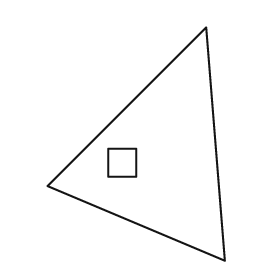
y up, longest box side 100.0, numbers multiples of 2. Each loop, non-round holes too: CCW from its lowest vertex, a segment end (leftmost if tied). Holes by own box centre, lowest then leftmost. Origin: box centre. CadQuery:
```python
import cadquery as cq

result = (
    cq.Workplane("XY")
    .moveTo(38.0, -50.0)
    .lineTo(30.0, 50.0)
    .lineTo(-38.0, -18.0)
    .close()
    .moveTo(-12.0, -14.0)
    .lineTo(0.0, -14.0)
    .lineTo(0.0, -2.0)
    .lineTo(-12.0, -2.0)
    .close()
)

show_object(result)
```